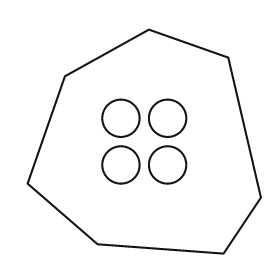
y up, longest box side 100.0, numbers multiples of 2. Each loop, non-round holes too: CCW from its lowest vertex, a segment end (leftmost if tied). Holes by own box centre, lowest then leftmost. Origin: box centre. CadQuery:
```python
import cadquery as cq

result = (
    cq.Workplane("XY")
    .moveTo(34.0, -48.0)
    .lineTo(50.0, -24.0)
    .lineTo(36.0, 36.0)
    .lineTo(2.0, 48.0)
    .lineTo(-34.0, 28.0)
    .lineTo(-50.0, -18.0)
    .lineTo(-20.0, -44.0)
    .close()
    .moveTo(-10.0, -10.0)
    .circle(8.0)
    .moveTo(10.0, -10.0)
    .circle(8.0)
    .moveTo(-10.0, 10.0)
    .circle(8.0)
    .moveTo(10.0, 10.0)
    .circle(8.0)
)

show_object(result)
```